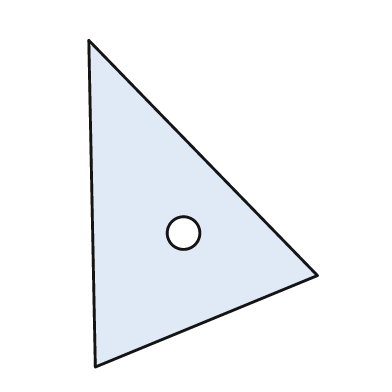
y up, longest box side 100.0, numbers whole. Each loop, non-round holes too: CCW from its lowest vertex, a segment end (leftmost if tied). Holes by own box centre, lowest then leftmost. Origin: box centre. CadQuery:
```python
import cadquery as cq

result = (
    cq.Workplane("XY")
    .moveTo(-33.0, -50.0)
    .lineTo(35.0, -22.0)
    .lineTo(-35.0, 50.0)
    .close()
    .moveTo(-6.0, -9.0)
    .circle(5.0)
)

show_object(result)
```